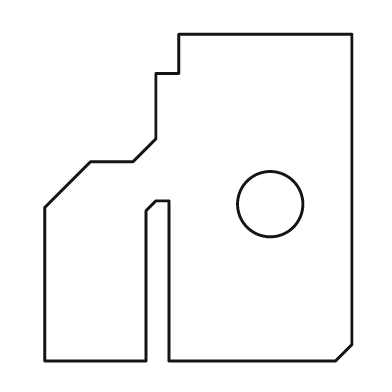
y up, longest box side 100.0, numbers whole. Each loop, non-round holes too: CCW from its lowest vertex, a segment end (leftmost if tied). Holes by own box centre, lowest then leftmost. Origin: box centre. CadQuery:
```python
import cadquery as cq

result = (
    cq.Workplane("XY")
    .moveTo(-47.0, -50.0)
    .lineTo(-16.0, -50.0)
    .lineTo(-16.0, -4.0)
    .lineTo(-13.0, -1.0)
    .lineTo(-9.0, -1.0)
    .lineTo(-9.0, -50.0)
    .lineTo(42.0, -50.0)
    .lineTo(47.0, -45.0)
    .lineTo(47.0, 50.0)
    .lineTo(-6.0, 50.0)
    .lineTo(-6.0, 38.0)
    .lineTo(-13.0, 38.0)
    .lineTo(-13.0, 18.0)
    .lineTo(-20.0, 11.0)
    .lineTo(-33.0, 11.0)
    .lineTo(-47.0, -3.0)
    .close()
    .moveTo(22.0, -2.0)
    .circle(10.0)
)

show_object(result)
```